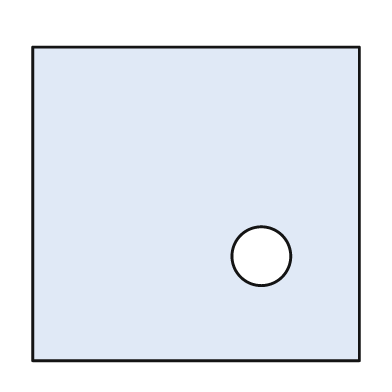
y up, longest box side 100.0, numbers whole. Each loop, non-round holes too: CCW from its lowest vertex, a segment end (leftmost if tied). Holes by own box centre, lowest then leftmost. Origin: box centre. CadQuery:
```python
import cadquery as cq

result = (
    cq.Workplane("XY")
    .moveTo(-50.0, -48.0)
    .lineTo(50.0, -48.0)
    .lineTo(50.0, 48.0)
    .lineTo(-50.0, 48.0)
    .close()
    .moveTo(20.0, -16.0)
    .circle(9.0)
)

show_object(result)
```